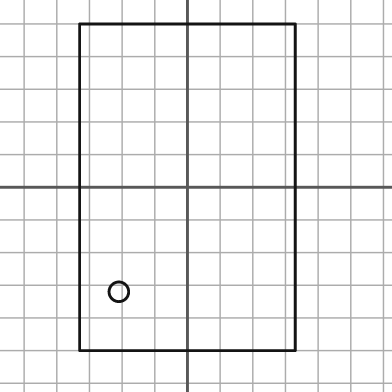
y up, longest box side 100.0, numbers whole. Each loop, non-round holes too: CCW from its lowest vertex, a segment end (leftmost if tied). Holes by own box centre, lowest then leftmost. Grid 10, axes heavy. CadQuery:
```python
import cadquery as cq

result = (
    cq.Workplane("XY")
    .moveTo(-33.0, -50.0)
    .lineTo(33.0, -50.0)
    .lineTo(33.0, 50.0)
    .lineTo(-33.0, 50.0)
    .close()
    .moveTo(-21.0, -32.0)
    .circle(3.0)
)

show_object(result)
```